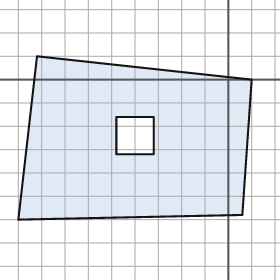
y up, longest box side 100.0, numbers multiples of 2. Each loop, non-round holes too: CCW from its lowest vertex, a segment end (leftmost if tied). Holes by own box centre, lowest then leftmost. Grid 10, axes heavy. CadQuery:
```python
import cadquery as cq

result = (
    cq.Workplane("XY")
    .moveTo(-90.0, -60.0)
    .lineTo(6.0, -58.0)
    .lineTo(10.0, 0.0)
    .lineTo(-82.0, 10.0)
    .close()
    .moveTo(-48.0, -32.0)
    .lineTo(-32.0, -32.0)
    .lineTo(-32.0, -16.0)
    .lineTo(-48.0, -16.0)
    .close()
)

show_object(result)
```